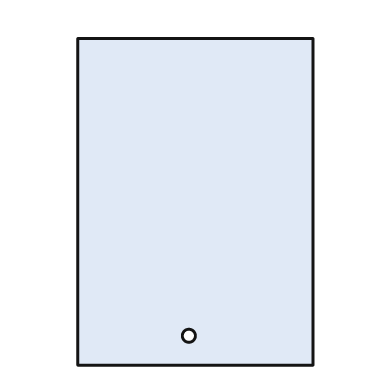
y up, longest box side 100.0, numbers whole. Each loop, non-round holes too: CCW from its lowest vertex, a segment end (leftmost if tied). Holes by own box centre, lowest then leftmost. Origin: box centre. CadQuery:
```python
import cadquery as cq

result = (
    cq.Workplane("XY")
    .moveTo(-36.0, -50.0)
    .lineTo(36.0, -50.0)
    .lineTo(36.0, 50.0)
    .lineTo(-36.0, 50.0)
    .close()
    .moveTo(-2.0, -41.0)
    .circle(2.0)
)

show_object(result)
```